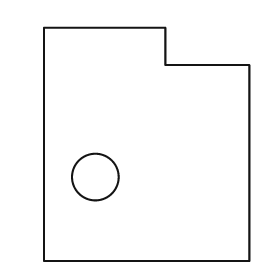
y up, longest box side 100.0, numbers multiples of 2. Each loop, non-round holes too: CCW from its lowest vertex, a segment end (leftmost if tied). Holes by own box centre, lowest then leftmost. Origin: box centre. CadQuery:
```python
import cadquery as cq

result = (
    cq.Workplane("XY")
    .moveTo(-44.0, -50.0)
    .lineTo(44.0, -50.0)
    .lineTo(44.0, 34.0)
    .lineTo(8.0, 34.0)
    .lineTo(8.0, 50.0)
    .lineTo(-44.0, 50.0)
    .close()
    .moveTo(-22.0, -14.0)
    .circle(10.0)
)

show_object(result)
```